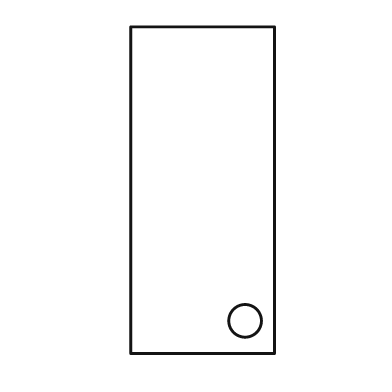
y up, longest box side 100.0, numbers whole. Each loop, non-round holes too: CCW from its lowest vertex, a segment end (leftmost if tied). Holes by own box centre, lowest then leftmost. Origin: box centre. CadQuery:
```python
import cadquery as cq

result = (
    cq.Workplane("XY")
    .moveTo(-22.0, -50.0)
    .lineTo(22.0, -50.0)
    .lineTo(22.0, 50.0)
    .lineTo(-22.0, 50.0)
    .close()
    .moveTo(13.0, -40.0)
    .circle(5.0)
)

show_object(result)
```